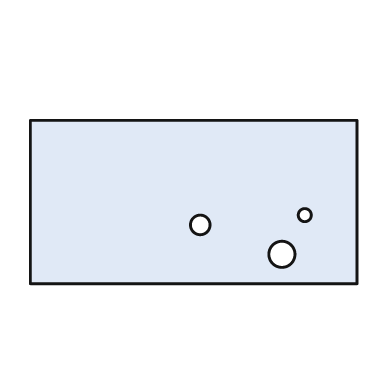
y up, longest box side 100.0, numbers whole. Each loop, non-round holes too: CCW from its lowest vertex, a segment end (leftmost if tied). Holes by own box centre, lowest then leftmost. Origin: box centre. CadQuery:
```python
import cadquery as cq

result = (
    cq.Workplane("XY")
    .moveTo(-50.0, -25.0)
    .lineTo(50.0, -25.0)
    .lineTo(50.0, 25.0)
    .lineTo(-50.0, 25.0)
    .close()
    .moveTo(27.0, -16.0)
    .circle(4.0)
    .moveTo(2.0, -7.0)
    .circle(3.0)
    .moveTo(34.0, -4.0)
    .circle(2.0)
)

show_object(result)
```